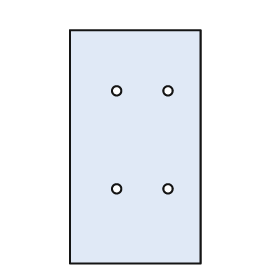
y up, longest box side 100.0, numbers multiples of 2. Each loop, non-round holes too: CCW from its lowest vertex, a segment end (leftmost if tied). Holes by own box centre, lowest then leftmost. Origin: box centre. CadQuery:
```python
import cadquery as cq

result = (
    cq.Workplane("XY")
    .moveTo(-28.0, -50.0)
    .lineTo(28.0, -50.0)
    .lineTo(28.0, 50.0)
    .lineTo(-28.0, 50.0)
    .close()
    .moveTo(-8.0, -18.0)
    .circle(2.0)
    .moveTo(14.0, -18.0)
    .circle(2.0)
    .moveTo(-8.0, 24.0)
    .circle(2.0)
    .moveTo(14.0, 24.0)
    .circle(2.0)
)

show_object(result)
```